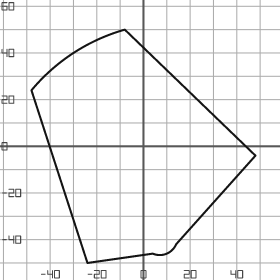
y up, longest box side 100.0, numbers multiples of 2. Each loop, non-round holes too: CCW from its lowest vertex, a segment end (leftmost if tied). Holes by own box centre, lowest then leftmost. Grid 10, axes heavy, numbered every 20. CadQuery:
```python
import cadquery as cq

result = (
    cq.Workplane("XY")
    .moveTo(-24.0, -50.0)
    .lineTo(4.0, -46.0)
    .threePointArc((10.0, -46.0), (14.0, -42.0))
    .lineTo(48.0, -4.0)
    .lineTo(-8.0, 50.0)
    .threePointArc((-30.0, 40.0), (-48.0, 24.0))
    .close()
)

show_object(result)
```